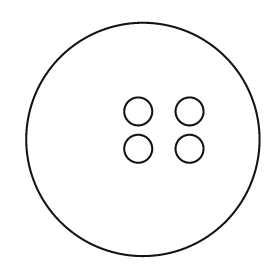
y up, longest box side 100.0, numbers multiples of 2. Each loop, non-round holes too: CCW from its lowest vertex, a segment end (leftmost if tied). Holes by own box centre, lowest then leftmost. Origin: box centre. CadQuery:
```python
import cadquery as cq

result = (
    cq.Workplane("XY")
    .moveTo(0.0, 0.0)
    .circle(50.0)
    .moveTo(-2.0, -4.0)
    .circle(6.0)
    .moveTo(20.0, -4.0)
    .circle(6.0)
    .moveTo(-2.0, 12.0)
    .circle(6.0)
    .moveTo(20.0, 12.0)
    .circle(6.0)
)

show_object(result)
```